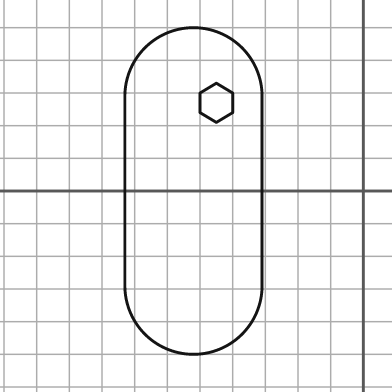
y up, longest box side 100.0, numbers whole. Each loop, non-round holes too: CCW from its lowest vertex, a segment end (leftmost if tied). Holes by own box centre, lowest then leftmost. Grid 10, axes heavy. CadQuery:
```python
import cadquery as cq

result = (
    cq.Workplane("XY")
    .moveTo(-73.0, -29.0)
    .threePointArc((-52.0, -50.0), (-31.0, -29.0))
    .lineTo(-31.0, 29.0)
    .threePointArc((-52.0, 50.0), (-73.0, 29.0))
    .close()
    .moveTo(-45.0, 21.0)
    .lineTo(-40.0, 24.0)
    .lineTo(-40.0, 30.0)
    .lineTo(-45.0, 33.0)
    .lineTo(-50.0, 30.0)
    .lineTo(-50.0, 24.0)
    .close()
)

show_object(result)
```